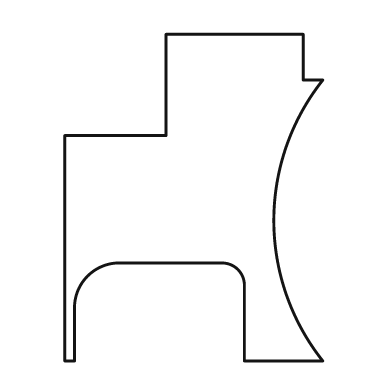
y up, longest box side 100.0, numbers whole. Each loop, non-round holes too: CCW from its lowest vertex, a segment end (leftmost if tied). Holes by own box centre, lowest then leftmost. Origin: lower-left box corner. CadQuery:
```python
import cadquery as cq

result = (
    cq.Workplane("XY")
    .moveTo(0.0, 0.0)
    .lineTo(3.0, 0.0)
    .lineTo(3.0, 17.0)
    .threePointArc((7.0, 26.0), (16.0, 30.0))
    .lineTo(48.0, 30.0)
    .threePointArc((53.0, 28.0), (55.0, 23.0))
    .lineTo(55.0, 0.0)
    .lineTo(79.0, 0.0)
    .threePointArc((64.0, 43.0), (79.0, 86.0))
    .lineTo(73.0, 86.0)
    .lineTo(73.0, 100.0)
    .lineTo(31.0, 100.0)
    .lineTo(31.0, 69.0)
    .lineTo(0.0, 69.0)
    .close()
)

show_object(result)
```